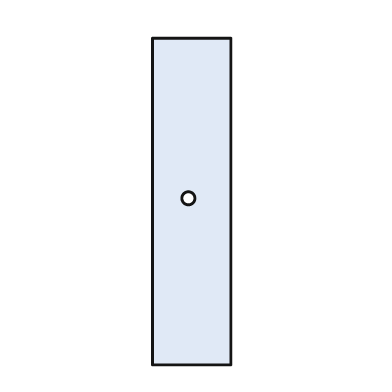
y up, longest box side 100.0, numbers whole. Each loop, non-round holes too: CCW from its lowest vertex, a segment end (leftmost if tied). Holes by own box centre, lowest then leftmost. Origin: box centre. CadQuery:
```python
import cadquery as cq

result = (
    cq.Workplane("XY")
    .moveTo(-12.0, -50.0)
    .lineTo(12.0, -50.0)
    .lineTo(12.0, 50.0)
    .lineTo(-12.0, 50.0)
    .close()
    .moveTo(-1.0, 1.0)
    .circle(2.0)
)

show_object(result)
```